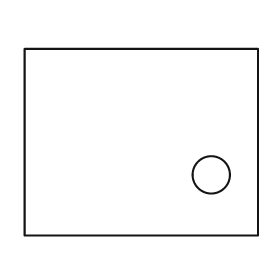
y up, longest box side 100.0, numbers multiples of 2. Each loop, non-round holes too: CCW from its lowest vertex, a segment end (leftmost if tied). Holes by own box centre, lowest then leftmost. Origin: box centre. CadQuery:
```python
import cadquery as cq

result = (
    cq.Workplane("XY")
    .moveTo(-50.0, -40.0)
    .lineTo(50.0, -40.0)
    .lineTo(50.0, 40.0)
    .lineTo(-50.0, 40.0)
    .close()
    .moveTo(30.0, -14.0)
    .circle(8.0)
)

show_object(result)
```